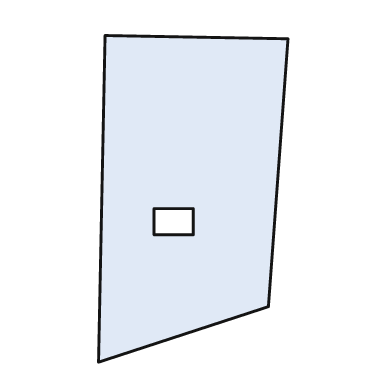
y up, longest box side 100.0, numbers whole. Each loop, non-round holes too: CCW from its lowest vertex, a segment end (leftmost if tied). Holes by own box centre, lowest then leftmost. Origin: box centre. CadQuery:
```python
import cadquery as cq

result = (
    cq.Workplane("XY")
    .moveTo(-29.0, -50.0)
    .lineTo(23.0, -33.0)
    .lineTo(29.0, 49.0)
    .lineTo(-27.0, 50.0)
    .close()
    .moveTo(-12.0, -11.0)
    .lineTo(0.0, -11.0)
    .lineTo(0.0, -3.0)
    .lineTo(-12.0, -3.0)
    .close()
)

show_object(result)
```